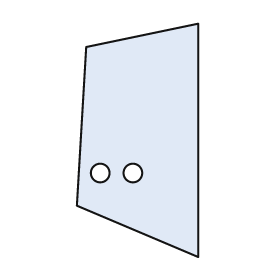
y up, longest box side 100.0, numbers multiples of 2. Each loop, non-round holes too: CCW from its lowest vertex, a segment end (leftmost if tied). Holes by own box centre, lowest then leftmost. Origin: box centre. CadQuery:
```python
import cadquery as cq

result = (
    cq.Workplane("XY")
    .moveTo(26.0, -50.0)
    .lineTo(26.0, 50.0)
    .lineTo(-22.0, 40.0)
    .lineTo(-26.0, -28.0)
    .close()
    .moveTo(-16.0, -14.0)
    .circle(4.0)
    .moveTo(-2.0, -14.0)
    .circle(4.0)
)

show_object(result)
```